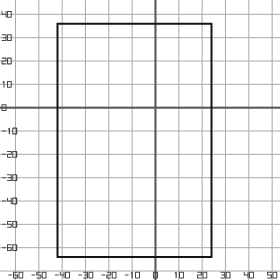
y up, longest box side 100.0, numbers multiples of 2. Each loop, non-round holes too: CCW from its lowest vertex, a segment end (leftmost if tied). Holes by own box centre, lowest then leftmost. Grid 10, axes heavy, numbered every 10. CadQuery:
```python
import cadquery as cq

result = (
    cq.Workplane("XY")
    .moveTo(-42.0, -64.0)
    .lineTo(24.0, -64.0)
    .lineTo(24.0, 36.0)
    .lineTo(-42.0, 36.0)
    .close()
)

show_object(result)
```